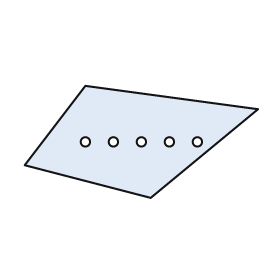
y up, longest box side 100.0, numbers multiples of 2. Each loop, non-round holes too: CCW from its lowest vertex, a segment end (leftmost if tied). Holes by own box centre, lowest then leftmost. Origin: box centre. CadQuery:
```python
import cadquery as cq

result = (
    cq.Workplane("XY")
    .moveTo(4.0, -24.0)
    .lineTo(50.0, 14.0)
    .lineTo(-24.0, 24.0)
    .lineTo(-50.0, -10.0)
    .close()
    .moveTo(-24.0, 0.0)
    .circle(2.0)
    .moveTo(-12.0, 0.0)
    .circle(2.0)
    .moveTo(0.0, 0.0)
    .circle(2.0)
    .moveTo(12.0, 0.0)
    .circle(2.0)
    .moveTo(24.0, 0.0)
    .circle(2.0)
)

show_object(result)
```